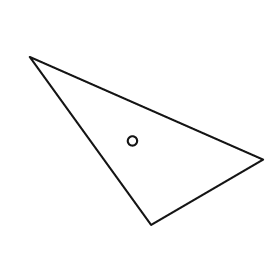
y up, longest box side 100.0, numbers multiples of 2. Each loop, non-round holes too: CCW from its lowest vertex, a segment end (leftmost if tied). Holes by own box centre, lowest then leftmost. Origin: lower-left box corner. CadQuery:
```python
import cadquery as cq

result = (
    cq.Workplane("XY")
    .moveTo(52.0, 0.0)
    .lineTo(100.0, 28.0)
    .lineTo(0.0, 72.0)
    .close()
    .moveTo(44.0, 36.0)
    .circle(2.0)
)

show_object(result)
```